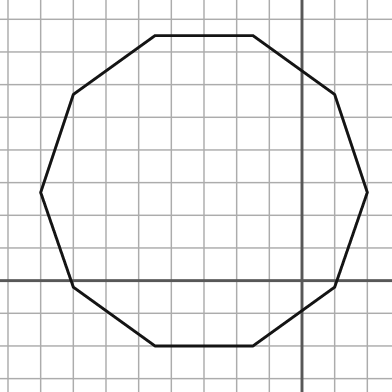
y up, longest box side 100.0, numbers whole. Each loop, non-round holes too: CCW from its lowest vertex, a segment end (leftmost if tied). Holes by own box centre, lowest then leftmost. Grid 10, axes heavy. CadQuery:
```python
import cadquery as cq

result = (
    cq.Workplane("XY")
    .moveTo(-45.0, -20.0)
    .lineTo(-15.0, -20.0)
    .lineTo(10.0, -2.0)
    .lineTo(20.0, 27.0)
    .lineTo(10.0, 57.0)
    .lineTo(-15.0, 75.0)
    .lineTo(-45.0, 75.0)
    .lineTo(-70.0, 57.0)
    .lineTo(-80.0, 27.0)
    .lineTo(-70.0, -2.0)
    .close()
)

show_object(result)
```